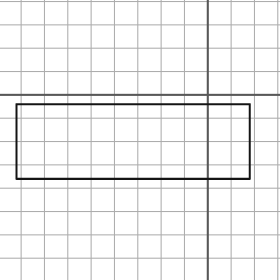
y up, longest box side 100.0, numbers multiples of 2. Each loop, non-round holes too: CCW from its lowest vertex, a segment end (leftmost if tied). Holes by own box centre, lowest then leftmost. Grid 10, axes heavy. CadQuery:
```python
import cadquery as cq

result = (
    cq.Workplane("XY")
    .moveTo(-82.0, -36.0)
    .lineTo(18.0, -36.0)
    .lineTo(18.0, -4.0)
    .lineTo(-82.0, -4.0)
    .close()
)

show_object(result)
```